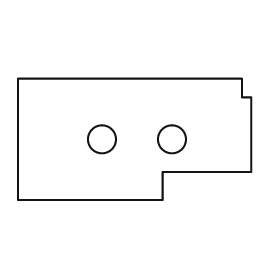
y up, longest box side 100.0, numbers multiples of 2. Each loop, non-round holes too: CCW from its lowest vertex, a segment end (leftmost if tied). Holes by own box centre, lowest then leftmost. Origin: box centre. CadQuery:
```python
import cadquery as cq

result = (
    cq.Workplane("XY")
    .moveTo(-50.0, -26.0)
    .lineTo(12.0, -26.0)
    .lineTo(12.0, -14.0)
    .lineTo(50.0, -14.0)
    .lineTo(50.0, 18.0)
    .lineTo(46.0, 18.0)
    .lineTo(46.0, 26.0)
    .lineTo(-50.0, 26.0)
    .close()
    .moveTo(-14.0, 0.0)
    .circle(6.0)
    .moveTo(16.0, 0.0)
    .circle(6.0)
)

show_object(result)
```